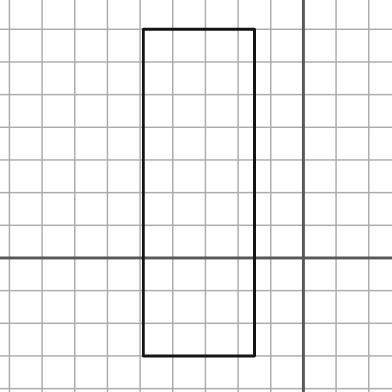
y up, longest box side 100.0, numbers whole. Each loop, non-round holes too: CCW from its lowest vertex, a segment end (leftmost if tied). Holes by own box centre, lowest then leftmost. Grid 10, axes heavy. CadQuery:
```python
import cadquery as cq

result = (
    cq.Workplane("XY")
    .moveTo(-49.0, -30.0)
    .lineTo(-15.0, -30.0)
    .lineTo(-15.0, 70.0)
    .lineTo(-49.0, 70.0)
    .close()
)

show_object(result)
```